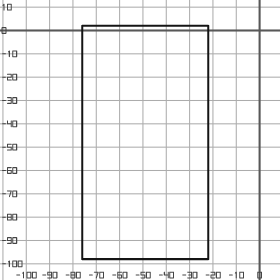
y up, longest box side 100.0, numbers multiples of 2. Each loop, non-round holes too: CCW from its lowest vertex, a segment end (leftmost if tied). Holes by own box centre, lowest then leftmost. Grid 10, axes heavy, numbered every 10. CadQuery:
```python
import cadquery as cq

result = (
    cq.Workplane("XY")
    .moveTo(-76.0, -98.0)
    .lineTo(-22.0, -98.0)
    .lineTo(-22.0, 2.0)
    .lineTo(-76.0, 2.0)
    .close()
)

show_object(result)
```